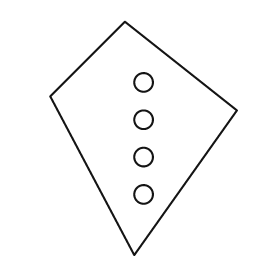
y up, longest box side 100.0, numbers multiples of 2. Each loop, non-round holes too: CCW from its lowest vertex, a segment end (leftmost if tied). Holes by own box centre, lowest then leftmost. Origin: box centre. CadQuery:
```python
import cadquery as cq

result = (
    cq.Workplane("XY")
    .moveTo(-4.0, -50.0)
    .lineTo(40.0, 12.0)
    .lineTo(-8.0, 50.0)
    .lineTo(-40.0, 18.0)
    .close()
    .moveTo(0.0, -24.0)
    .circle(4.0)
    .moveTo(0.0, -8.0)
    .circle(4.0)
    .moveTo(0.0, 8.0)
    .circle(4.0)
    .moveTo(0.0, 24.0)
    .circle(4.0)
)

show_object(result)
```